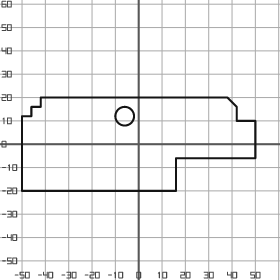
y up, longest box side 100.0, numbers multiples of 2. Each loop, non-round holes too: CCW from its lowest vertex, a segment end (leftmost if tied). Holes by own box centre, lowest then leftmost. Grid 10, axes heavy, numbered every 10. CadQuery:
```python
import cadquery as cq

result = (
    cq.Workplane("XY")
    .moveTo(-50.0, -20.0)
    .lineTo(16.0, -20.0)
    .lineTo(16.0, -6.0)
    .lineTo(50.0, -6.0)
    .lineTo(50.0, 10.0)
    .lineTo(42.0, 10.0)
    .lineTo(42.0, 16.0)
    .lineTo(38.0, 20.0)
    .lineTo(-42.0, 20.0)
    .lineTo(-42.0, 16.0)
    .lineTo(-46.0, 16.0)
    .lineTo(-46.0, 12.0)
    .lineTo(-50.0, 12.0)
    .close()
    .moveTo(-6.0, 12.0)
    .circle(4.0)
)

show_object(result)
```